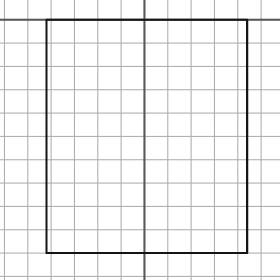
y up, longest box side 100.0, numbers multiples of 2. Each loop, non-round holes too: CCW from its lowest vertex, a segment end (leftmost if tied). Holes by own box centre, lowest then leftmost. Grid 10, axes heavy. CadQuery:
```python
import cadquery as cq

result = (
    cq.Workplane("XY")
    .moveTo(-42.0, -100.0)
    .lineTo(44.0, -100.0)
    .lineTo(44.0, 0.0)
    .lineTo(-42.0, 0.0)
    .close()
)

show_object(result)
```